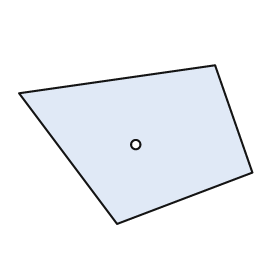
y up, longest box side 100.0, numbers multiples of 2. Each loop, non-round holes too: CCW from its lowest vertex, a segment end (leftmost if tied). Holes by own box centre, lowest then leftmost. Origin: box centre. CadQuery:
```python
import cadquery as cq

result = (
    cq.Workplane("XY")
    .moveTo(-8.0, -34.0)
    .lineTo(50.0, -12.0)
    .lineTo(34.0, 34.0)
    .lineTo(-50.0, 22.0)
    .close()
    .moveTo(0.0, 0.0)
    .circle(2.0)
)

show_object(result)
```